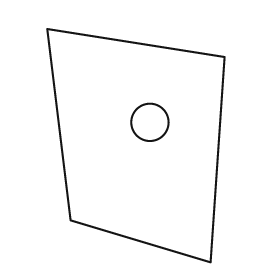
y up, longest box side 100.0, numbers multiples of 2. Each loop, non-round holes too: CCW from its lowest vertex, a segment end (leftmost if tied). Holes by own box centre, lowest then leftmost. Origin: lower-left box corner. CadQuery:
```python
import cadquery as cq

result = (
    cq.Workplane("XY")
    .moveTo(70.0, 0.0)
    .lineTo(76.0, 88.0)
    .lineTo(0.0, 100.0)
    .lineTo(10.0, 18.0)
    .close()
    .moveTo(44.0, 60.0)
    .circle(8.0)
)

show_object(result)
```